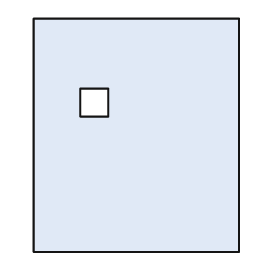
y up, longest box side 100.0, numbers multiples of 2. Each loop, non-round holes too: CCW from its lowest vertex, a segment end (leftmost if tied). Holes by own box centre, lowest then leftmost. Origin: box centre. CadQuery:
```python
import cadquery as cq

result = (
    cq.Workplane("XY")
    .moveTo(-44.0, -50.0)
    .lineTo(44.0, -50.0)
    .lineTo(44.0, 50.0)
    .lineTo(-44.0, 50.0)
    .close()
    .moveTo(-24.0, 8.0)
    .lineTo(-12.0, 8.0)
    .lineTo(-12.0, 20.0)
    .lineTo(-24.0, 20.0)
    .close()
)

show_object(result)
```